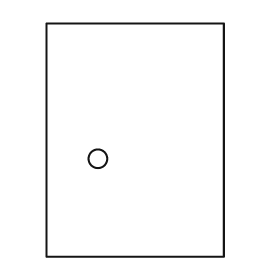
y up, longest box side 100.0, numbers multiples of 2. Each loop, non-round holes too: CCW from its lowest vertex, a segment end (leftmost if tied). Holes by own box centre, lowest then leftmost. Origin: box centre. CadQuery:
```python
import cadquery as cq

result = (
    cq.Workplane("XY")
    .moveTo(-38.0, -50.0)
    .lineTo(38.0, -50.0)
    .lineTo(38.0, 50.0)
    .lineTo(-38.0, 50.0)
    .close()
    .moveTo(-16.0, -8.0)
    .circle(4.0)
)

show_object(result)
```